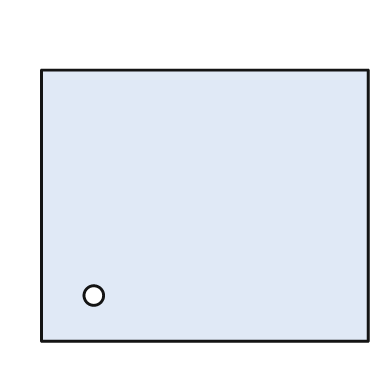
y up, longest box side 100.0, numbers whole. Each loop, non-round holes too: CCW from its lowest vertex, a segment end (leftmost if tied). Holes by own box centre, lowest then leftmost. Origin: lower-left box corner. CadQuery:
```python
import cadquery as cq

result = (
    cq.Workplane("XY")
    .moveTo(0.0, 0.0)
    .lineTo(100.0, 0.0)
    .lineTo(100.0, 83.0)
    .lineTo(0.0, 83.0)
    .close()
    .moveTo(16.0, 14.0)
    .circle(3.0)
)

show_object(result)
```